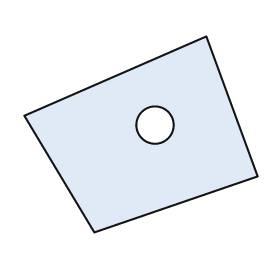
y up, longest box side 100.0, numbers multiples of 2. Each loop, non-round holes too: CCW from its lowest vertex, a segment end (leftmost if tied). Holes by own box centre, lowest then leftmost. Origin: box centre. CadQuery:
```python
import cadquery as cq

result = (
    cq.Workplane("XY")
    .moveTo(-20.0, -42.0)
    .lineTo(50.0, -18.0)
    .lineTo(28.0, 42.0)
    .lineTo(-50.0, 8.0)
    .close()
    .moveTo(6.0, 4.0)
    .circle(8.0)
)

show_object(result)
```